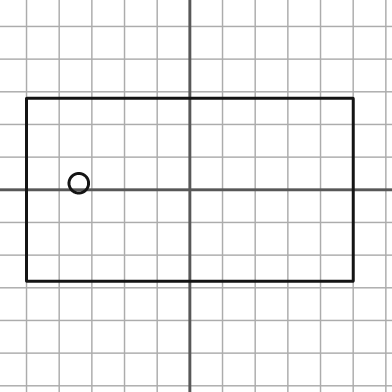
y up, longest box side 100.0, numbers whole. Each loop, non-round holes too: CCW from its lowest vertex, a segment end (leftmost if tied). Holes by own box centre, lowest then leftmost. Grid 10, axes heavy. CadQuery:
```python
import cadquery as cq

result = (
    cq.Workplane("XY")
    .moveTo(-50.0, -28.0)
    .lineTo(50.0, -28.0)
    .lineTo(50.0, 28.0)
    .lineTo(-50.0, 28.0)
    .close()
    .moveTo(-34.0, 2.0)
    .circle(3.0)
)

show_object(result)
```